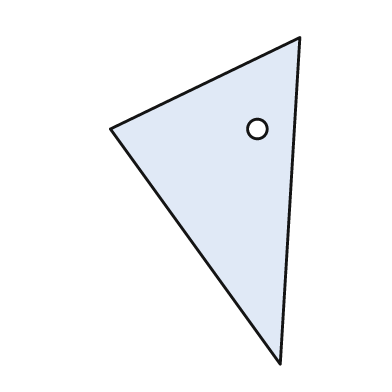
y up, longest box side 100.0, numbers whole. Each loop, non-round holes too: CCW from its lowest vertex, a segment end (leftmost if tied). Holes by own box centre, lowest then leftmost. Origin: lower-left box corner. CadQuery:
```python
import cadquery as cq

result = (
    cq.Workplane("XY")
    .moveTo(52.0, 0.0)
    .lineTo(58.0, 100.0)
    .lineTo(0.0, 72.0)
    .close()
    .moveTo(45.0, 72.0)
    .circle(3.0)
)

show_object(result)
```